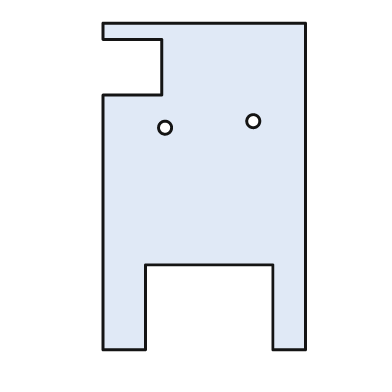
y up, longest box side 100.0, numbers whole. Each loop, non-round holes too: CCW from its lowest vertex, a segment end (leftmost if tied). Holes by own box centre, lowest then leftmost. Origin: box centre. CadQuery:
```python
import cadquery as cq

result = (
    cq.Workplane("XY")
    .moveTo(-31.0, -50.0)
    .lineTo(-18.0, -50.0)
    .lineTo(-18.0, -24.0)
    .lineTo(21.0, -24.0)
    .lineTo(21.0, -50.0)
    .lineTo(31.0, -50.0)
    .lineTo(31.0, 50.0)
    .lineTo(-31.0, 50.0)
    .lineTo(-31.0, 45.0)
    .lineTo(-13.0, 45.0)
    .lineTo(-13.0, 28.0)
    .lineTo(-31.0, 28.0)
    .close()
    .moveTo(-12.0, 18.0)
    .circle(2.0)
    .moveTo(15.0, 20.0)
    .circle(2.0)
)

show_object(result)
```